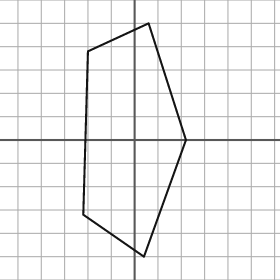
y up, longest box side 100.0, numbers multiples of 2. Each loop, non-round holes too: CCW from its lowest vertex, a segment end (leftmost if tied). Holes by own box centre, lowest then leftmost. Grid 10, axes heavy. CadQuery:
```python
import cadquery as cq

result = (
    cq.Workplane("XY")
    .moveTo(4.0, -50.0)
    .lineTo(22.0, 0.0)
    .lineTo(6.0, 50.0)
    .lineTo(-20.0, 38.0)
    .lineTo(-22.0, -32.0)
    .close()
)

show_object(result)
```